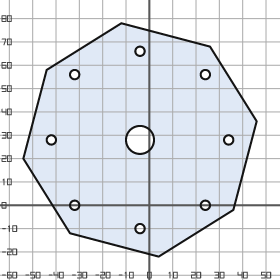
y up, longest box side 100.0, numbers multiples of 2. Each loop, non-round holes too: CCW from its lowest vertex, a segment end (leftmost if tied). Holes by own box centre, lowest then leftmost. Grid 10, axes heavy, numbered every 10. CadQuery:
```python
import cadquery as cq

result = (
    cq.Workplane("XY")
    .moveTo(4.0, -22.0)
    .lineTo(36.0, -2.0)
    .lineTo(46.0, 36.0)
    .lineTo(26.0, 68.0)
    .lineTo(-12.0, 78.0)
    .lineTo(-44.0, 58.0)
    .lineTo(-54.0, 20.0)
    .lineTo(-34.0, -12.0)
    .close()
    .moveTo(-4.0, -10.0)
    .circle(2.0)
    .moveTo(-32.0, 0.0)
    .circle(2.0)
    .moveTo(24.0, 0.0)
    .circle(2.0)
    .moveTo(-42.0, 28.0)
    .circle(2.0)
    .moveTo(-4.0, 28.0)
    .circle(6.0)
    .moveTo(34.0, 28.0)
    .circle(2.0)
    .moveTo(-32.0, 56.0)
    .circle(2.0)
    .moveTo(24.0, 56.0)
    .circle(2.0)
    .moveTo(-4.0, 66.0)
    .circle(2.0)
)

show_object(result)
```